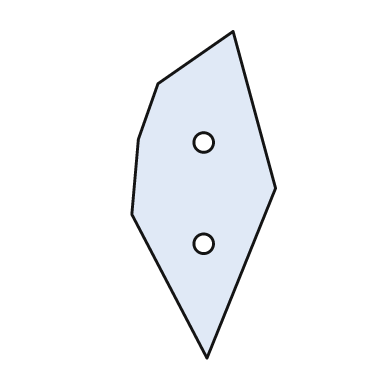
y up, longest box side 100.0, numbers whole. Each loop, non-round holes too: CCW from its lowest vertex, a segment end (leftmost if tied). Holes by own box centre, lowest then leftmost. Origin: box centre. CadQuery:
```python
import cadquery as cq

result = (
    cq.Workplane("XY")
    .moveTo(1.0, -50.0)
    .lineTo(22.0, 2.0)
    .lineTo(9.0, 50.0)
    .lineTo(-14.0, 34.0)
    .lineTo(-20.0, 17.0)
    .lineTo(-22.0, -6.0)
    .close()
    .moveTo(0.0, -15.0)
    .circle(3.0)
    .moveTo(0.0, 16.0)
    .circle(3.0)
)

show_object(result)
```